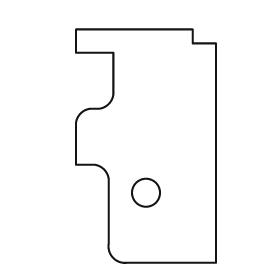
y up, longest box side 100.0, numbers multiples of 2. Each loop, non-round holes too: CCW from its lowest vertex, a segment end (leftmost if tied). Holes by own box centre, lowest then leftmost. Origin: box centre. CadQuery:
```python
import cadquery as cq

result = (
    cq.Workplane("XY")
    .moveTo(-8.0, -50.0)
    .lineTo(30.0, -50.0)
    .lineTo(30.0, 44.0)
    .lineTo(20.0, 44.0)
    .lineTo(20.0, 50.0)
    .lineTo(-30.0, 50.0)
    .lineTo(-30.0, 40.0)
    .lineTo(-14.0, 40.0)
    .lineTo(-14.0, 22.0)
    .threePointArc((-16.0, 18.0), (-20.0, 16.0))
    .lineTo(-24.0, 16.0)
    .threePointArc((-28.0, 14.0), (-30.0, 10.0))
    .lineTo(-30.0, -8.0)
    .lineTo(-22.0, -8.0)
    .threePointArc((-18.0, -10.0), (-16.0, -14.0))
    .lineTo(-16.0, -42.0)
    .threePointArc((-14.0, -48.0), (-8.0, -50.0))
    .close()
    .moveTo(0.0, -20.0)
    .circle(6.0)
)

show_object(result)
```